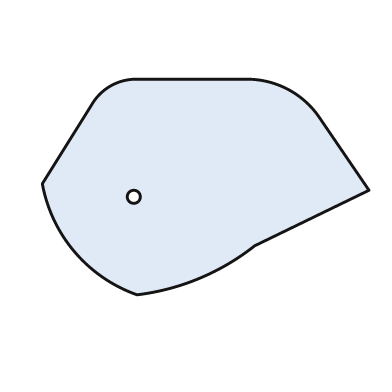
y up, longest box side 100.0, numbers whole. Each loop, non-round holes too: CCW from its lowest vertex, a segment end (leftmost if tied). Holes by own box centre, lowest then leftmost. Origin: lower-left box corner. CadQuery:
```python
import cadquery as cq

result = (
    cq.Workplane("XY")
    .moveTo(29.0, 0.0)
    .threePointArc((48.0, 5.0), (65.0, 15.0))
    .lineTo(100.0, 32.0)
    .lineTo(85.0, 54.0)
    .threePointArc((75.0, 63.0), (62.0, 66.0))
    .lineTo(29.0, 66.0)
    .threePointArc((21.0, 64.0), (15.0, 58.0))
    .lineTo(0.0, 34.0)
    .threePointArc((10.0, 13.0), (29.0, 0.0))
    .close()
    .moveTo(28.0, 30.0)
    .circle(2.0)
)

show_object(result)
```